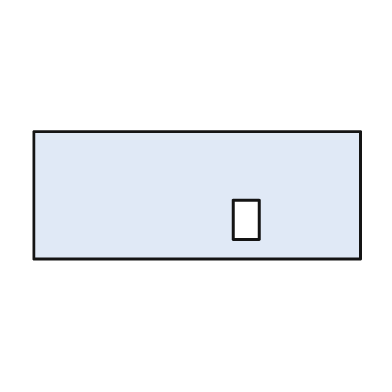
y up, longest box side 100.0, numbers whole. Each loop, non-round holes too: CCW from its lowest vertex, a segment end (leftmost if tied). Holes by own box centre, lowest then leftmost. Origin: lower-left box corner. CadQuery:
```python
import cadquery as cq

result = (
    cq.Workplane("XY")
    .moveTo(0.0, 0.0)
    .lineTo(100.0, 0.0)
    .lineTo(100.0, 39.0)
    .lineTo(0.0, 39.0)
    .close()
    .moveTo(61.0, 6.0)
    .lineTo(69.0, 6.0)
    .lineTo(69.0, 18.0)
    .lineTo(61.0, 18.0)
    .close()
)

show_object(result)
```